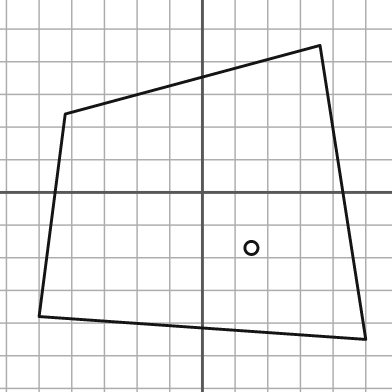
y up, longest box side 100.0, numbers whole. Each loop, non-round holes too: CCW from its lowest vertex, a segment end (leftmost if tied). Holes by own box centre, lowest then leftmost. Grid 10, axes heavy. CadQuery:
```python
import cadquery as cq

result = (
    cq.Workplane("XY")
    .moveTo(50.0, -45.0)
    .lineTo(36.0, 45.0)
    .lineTo(-42.0, 24.0)
    .lineTo(-50.0, -38.0)
    .close()
    .moveTo(15.0, -17.0)
    .circle(2.0)
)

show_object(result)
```